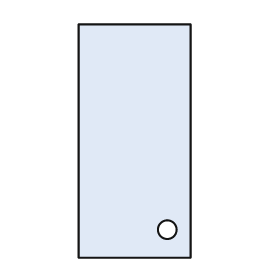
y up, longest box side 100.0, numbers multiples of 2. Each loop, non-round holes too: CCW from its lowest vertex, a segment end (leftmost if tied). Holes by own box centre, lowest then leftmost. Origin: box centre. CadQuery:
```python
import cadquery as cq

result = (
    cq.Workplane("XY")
    .moveTo(-24.0, -50.0)
    .lineTo(24.0, -50.0)
    .lineTo(24.0, 50.0)
    .lineTo(-24.0, 50.0)
    .close()
    .moveTo(14.0, -38.0)
    .circle(4.0)
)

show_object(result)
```